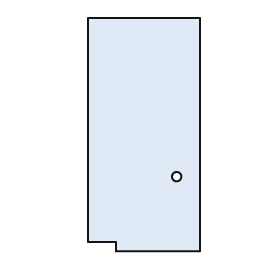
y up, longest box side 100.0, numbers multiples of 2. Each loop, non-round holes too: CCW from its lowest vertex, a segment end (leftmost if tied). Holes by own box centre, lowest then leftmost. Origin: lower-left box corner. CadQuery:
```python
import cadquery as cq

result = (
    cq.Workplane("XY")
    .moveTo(12.0, 0.0)
    .lineTo(48.0, 0.0)
    .lineTo(48.0, 100.0)
    .lineTo(0.0, 100.0)
    .lineTo(0.0, 4.0)
    .lineTo(12.0, 4.0)
    .close()
    .moveTo(38.0, 32.0)
    .circle(2.0)
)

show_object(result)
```